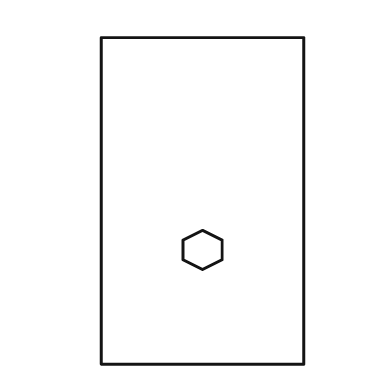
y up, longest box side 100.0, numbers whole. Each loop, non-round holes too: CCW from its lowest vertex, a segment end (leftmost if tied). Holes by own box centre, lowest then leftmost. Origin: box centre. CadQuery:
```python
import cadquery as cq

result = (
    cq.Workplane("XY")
    .moveTo(-31.0, -50.0)
    .lineTo(31.0, -50.0)
    .lineTo(31.0, 50.0)
    .lineTo(-31.0, 50.0)
    .close()
    .moveTo(0.0, -21.0)
    .lineTo(6.0, -18.0)
    .lineTo(6.0, -12.0)
    .lineTo(0.0, -9.0)
    .lineTo(-6.0, -12.0)
    .lineTo(-6.0, -18.0)
    .close()
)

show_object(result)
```